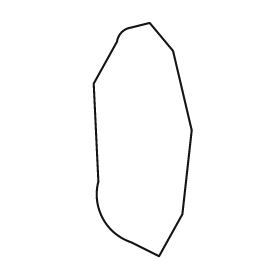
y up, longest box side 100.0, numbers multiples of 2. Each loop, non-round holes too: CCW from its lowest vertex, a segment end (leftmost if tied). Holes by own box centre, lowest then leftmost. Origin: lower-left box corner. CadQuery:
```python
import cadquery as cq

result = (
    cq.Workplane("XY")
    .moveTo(28.0, 0.0)
    .lineTo(38.0, 18.0)
    .lineTo(42.0, 54.0)
    .lineTo(34.0, 88.0)
    .lineTo(24.0, 100.0)
    .lineTo(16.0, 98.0)
    .threePointArc((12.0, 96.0), (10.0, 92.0))
    .lineTo(0.0, 74.0)
    .lineTo(2.0, 32.0)
    .threePointArc((4.0, 16.0), (16.0, 6.0))
    .close()
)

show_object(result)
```